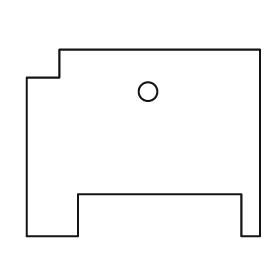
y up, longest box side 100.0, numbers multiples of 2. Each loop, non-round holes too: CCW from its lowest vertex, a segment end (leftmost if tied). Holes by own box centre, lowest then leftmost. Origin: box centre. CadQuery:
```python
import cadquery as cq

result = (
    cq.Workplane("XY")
    .moveTo(-50.0, -40.0)
    .lineTo(-28.0, -40.0)
    .lineTo(-28.0, -22.0)
    .lineTo(42.0, -22.0)
    .lineTo(42.0, -40.0)
    .lineTo(50.0, -40.0)
    .lineTo(50.0, 40.0)
    .lineTo(-36.0, 40.0)
    .lineTo(-36.0, 28.0)
    .lineTo(-50.0, 28.0)
    .close()
    .moveTo(2.0, 22.0)
    .circle(4.0)
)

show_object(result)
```